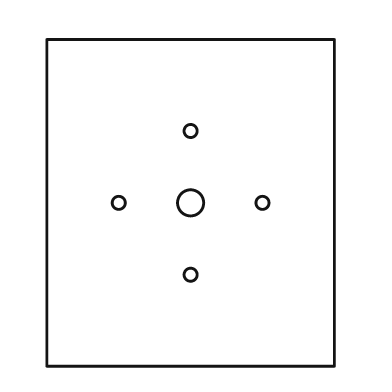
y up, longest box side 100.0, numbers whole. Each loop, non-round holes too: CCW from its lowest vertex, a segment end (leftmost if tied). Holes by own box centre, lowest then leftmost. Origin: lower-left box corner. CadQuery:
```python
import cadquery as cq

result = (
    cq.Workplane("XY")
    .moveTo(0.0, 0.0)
    .lineTo(88.0, 0.0)
    .lineTo(88.0, 100.0)
    .lineTo(0.0, 100.0)
    .close()
    .moveTo(44.0, 28.0)
    .circle(2.0)
    .moveTo(22.0, 50.0)
    .circle(2.0)
    .moveTo(44.0, 50.0)
    .circle(4.0)
    .moveTo(66.0, 50.0)
    .circle(2.0)
    .moveTo(44.0, 72.0)
    .circle(2.0)
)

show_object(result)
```